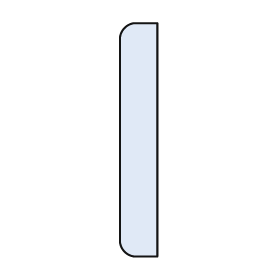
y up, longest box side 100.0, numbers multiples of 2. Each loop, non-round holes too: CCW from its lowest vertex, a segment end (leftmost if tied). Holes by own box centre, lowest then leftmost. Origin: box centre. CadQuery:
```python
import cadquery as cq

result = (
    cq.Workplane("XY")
    .moveTo(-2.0, -50.0)
    .lineTo(8.0, -50.0)
    .lineTo(8.0, 50.0)
    .lineTo(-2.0, 50.0)
    .threePointArc((-6.0, 48.0), (-8.0, 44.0))
    .lineTo(-8.0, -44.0)
    .threePointArc((-6.0, -48.0), (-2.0, -50.0))
    .close()
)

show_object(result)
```